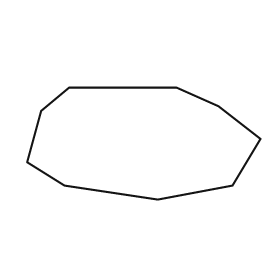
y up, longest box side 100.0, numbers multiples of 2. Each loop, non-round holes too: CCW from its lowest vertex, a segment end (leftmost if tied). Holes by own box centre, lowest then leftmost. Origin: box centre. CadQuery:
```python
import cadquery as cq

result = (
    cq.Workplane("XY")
    .moveTo(6.0, -24.0)
    .lineTo(38.0, -18.0)
    .lineTo(50.0, 2.0)
    .lineTo(32.0, 16.0)
    .lineTo(14.0, 24.0)
    .lineTo(-32.0, 24.0)
    .lineTo(-44.0, 14.0)
    .lineTo(-50.0, -8.0)
    .lineTo(-34.0, -18.0)
    .close()
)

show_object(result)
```